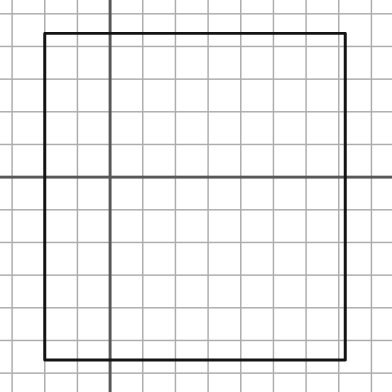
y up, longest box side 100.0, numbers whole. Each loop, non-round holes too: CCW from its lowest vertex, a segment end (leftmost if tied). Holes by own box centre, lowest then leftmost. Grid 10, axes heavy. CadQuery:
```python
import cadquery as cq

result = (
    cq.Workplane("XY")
    .moveTo(-20.0, -56.0)
    .lineTo(72.0, -56.0)
    .lineTo(72.0, 44.0)
    .lineTo(-20.0, 44.0)
    .close()
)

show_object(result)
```